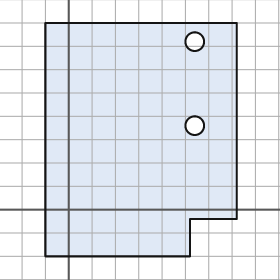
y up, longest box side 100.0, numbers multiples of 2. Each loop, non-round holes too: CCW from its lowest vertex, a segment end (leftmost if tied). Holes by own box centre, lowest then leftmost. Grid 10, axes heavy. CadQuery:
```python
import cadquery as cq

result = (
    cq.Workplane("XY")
    .moveTo(-10.0, -20.0)
    .lineTo(52.0, -20.0)
    .lineTo(52.0, -4.0)
    .lineTo(72.0, -4.0)
    .lineTo(72.0, 80.0)
    .lineTo(-10.0, 80.0)
    .close()
    .moveTo(54.0, 36.0)
    .circle(4.0)
    .moveTo(54.0, 72.0)
    .circle(4.0)
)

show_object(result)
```